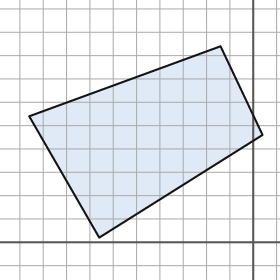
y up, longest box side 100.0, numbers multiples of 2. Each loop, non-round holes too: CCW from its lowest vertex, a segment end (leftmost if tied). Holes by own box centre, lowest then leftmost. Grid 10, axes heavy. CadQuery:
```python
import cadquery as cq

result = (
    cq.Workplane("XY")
    .moveTo(-66.0, 2.0)
    .lineTo(4.0, 46.0)
    .lineTo(-14.0, 84.0)
    .lineTo(-96.0, 54.0)
    .close()
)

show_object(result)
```